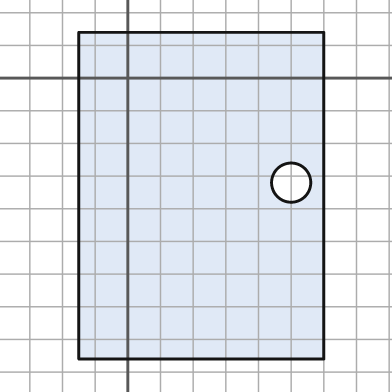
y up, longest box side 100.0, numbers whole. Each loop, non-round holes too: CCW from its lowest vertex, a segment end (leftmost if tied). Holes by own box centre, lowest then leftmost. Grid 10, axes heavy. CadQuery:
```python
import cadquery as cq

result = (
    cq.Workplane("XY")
    .moveTo(-15.0, -86.0)
    .lineTo(60.0, -86.0)
    .lineTo(60.0, 14.0)
    .lineTo(-15.0, 14.0)
    .close()
    .moveTo(50.0, -32.0)
    .circle(6.0)
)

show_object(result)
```